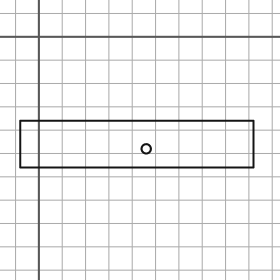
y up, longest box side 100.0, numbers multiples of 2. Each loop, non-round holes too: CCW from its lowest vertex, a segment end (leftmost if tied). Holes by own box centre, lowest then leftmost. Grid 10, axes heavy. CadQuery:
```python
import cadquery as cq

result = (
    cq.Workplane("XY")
    .moveTo(-8.0, -56.0)
    .lineTo(92.0, -56.0)
    .lineTo(92.0, -36.0)
    .lineTo(-8.0, -36.0)
    .close()
    .moveTo(46.0, -48.0)
    .circle(2.0)
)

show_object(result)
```